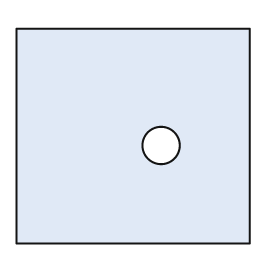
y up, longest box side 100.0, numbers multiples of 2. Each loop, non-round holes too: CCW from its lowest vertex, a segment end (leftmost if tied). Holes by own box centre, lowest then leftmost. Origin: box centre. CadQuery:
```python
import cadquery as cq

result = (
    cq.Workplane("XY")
    .moveTo(-50.0, -46.0)
    .lineTo(50.0, -46.0)
    .lineTo(50.0, 46.0)
    .lineTo(-50.0, 46.0)
    .close()
    .moveTo(12.0, -4.0)
    .circle(8.0)
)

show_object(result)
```